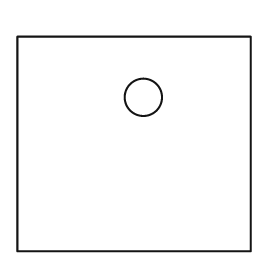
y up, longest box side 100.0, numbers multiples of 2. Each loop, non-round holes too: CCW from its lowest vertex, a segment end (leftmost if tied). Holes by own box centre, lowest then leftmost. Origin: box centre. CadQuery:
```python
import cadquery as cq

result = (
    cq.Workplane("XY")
    .moveTo(-50.0, -46.0)
    .lineTo(50.0, -46.0)
    .lineTo(50.0, 46.0)
    .lineTo(-50.0, 46.0)
    .close()
    .moveTo(4.0, 20.0)
    .circle(8.0)
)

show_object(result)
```